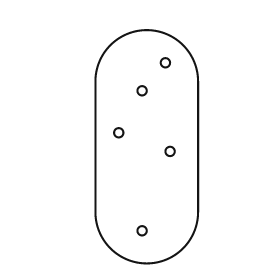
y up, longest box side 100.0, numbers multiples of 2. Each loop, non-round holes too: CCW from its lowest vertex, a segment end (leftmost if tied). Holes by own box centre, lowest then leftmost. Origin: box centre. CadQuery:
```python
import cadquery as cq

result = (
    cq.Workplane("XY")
    .moveTo(-22.0, -28.0)
    .threePointArc((0.0, -50.0), (22.0, -28.0))
    .lineTo(22.0, 28.0)
    .threePointArc((0.0, 50.0), (-22.0, 28.0))
    .close()
    .moveTo(-2.0, -36.0)
    .circle(2.0)
    .moveTo(10.0, -2.0)
    .circle(2.0)
    .moveTo(-12.0, 6.0)
    .circle(2.0)
    .moveTo(-2.0, 24.0)
    .circle(2.0)
    .moveTo(8.0, 36.0)
    .circle(2.0)
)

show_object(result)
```